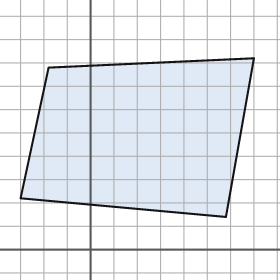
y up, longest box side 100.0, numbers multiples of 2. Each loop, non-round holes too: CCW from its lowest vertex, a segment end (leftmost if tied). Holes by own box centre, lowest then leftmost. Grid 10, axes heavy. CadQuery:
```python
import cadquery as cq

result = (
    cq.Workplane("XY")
    .moveTo(58.0, 14.0)
    .lineTo(70.0, 82.0)
    .lineTo(-18.0, 78.0)
    .lineTo(-30.0, 22.0)
    .close()
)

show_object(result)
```